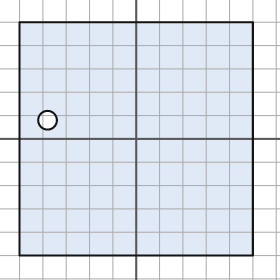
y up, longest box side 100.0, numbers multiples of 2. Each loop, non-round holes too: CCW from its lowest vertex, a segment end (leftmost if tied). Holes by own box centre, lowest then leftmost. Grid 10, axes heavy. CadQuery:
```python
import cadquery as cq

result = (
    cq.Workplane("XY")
    .moveTo(-50.0, -50.0)
    .lineTo(50.0, -50.0)
    .lineTo(50.0, 50.0)
    .lineTo(-50.0, 50.0)
    .close()
    .moveTo(-38.0, 8.0)
    .circle(4.0)
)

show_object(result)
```